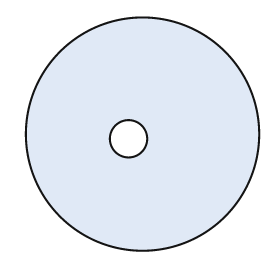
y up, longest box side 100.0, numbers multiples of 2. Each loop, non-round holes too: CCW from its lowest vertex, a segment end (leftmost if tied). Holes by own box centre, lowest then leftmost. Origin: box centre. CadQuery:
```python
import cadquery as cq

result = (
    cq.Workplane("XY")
    .moveTo(0.0, 0.0)
    .circle(50.0)
    .moveTo(-6.0, -2.0)
    .circle(8.0)
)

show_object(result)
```